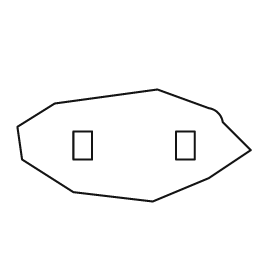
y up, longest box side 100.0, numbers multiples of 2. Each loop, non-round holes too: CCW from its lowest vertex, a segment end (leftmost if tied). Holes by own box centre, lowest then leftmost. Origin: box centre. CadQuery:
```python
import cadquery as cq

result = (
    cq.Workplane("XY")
    .moveTo(8.0, -24.0)
    .lineTo(32.0, -14.0)
    .lineTo(50.0, -2.0)
    .lineTo(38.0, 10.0)
    .threePointArc((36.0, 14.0), (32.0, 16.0))
    .lineTo(10.0, 24.0)
    .lineTo(-34.0, 18.0)
    .lineTo(-50.0, 8.0)
    .lineTo(-48.0, -6.0)
    .lineTo(-26.0, -20.0)
    .close()
    .moveTo(-26.0, -6.0)
    .lineTo(-18.0, -6.0)
    .lineTo(-18.0, 6.0)
    .lineTo(-26.0, 6.0)
    .close()
    .moveTo(18.0, -6.0)
    .lineTo(26.0, -6.0)
    .lineTo(26.0, 6.0)
    .lineTo(18.0, 6.0)
    .close()
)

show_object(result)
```